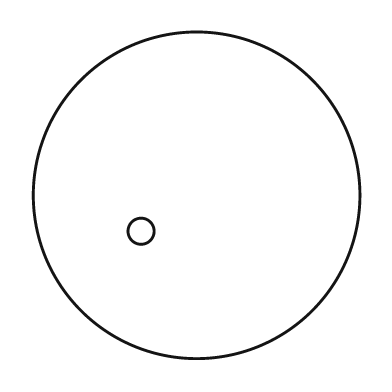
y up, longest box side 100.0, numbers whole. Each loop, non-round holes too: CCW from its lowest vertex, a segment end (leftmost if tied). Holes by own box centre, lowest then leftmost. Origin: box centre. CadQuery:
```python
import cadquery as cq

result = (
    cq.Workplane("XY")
    .moveTo(0.0, 0.0)
    .circle(50.0)
    .moveTo(-17.0, -11.0)
    .circle(4.0)
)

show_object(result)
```